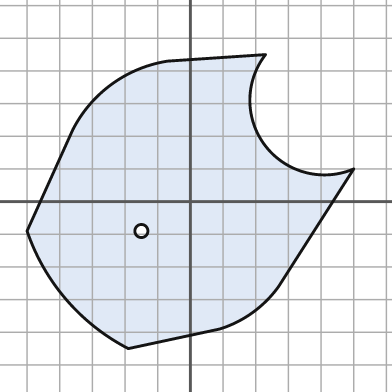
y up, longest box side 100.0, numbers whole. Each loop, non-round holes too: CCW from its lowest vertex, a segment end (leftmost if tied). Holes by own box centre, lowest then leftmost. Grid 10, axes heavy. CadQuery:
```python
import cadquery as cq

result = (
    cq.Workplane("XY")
    .moveTo(-19.0, -45.0)
    .lineTo(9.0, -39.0)
    .threePointArc((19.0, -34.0), (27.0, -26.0))
    .lineTo(50.0, 10.0)
    .threePointArc((23.0, 17.0), (23.0, 45.0))
    .lineTo(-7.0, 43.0)
    .threePointArc((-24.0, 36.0), (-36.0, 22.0))
    .lineTo(-50.0, -9.0)
    .threePointArc((-38.0, -30.0), (-19.0, -45.0))
    .close()
    .moveTo(-15.0, -9.0)
    .circle(2.0)
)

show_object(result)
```